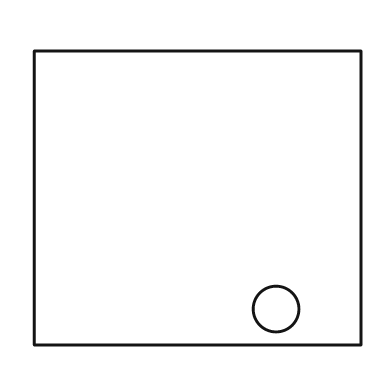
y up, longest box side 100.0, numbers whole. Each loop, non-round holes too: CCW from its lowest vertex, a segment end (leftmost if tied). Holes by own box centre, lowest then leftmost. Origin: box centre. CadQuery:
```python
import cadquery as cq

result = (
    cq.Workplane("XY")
    .moveTo(-50.0, -45.0)
    .lineTo(50.0, -45.0)
    .lineTo(50.0, 45.0)
    .lineTo(-50.0, 45.0)
    .close()
    .moveTo(24.0, -34.0)
    .circle(7.0)
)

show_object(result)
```